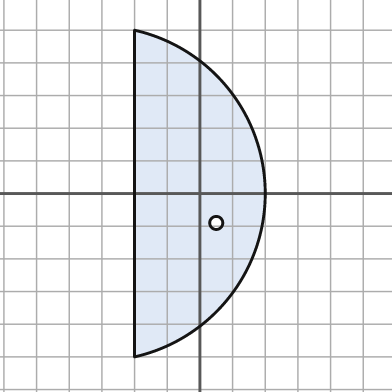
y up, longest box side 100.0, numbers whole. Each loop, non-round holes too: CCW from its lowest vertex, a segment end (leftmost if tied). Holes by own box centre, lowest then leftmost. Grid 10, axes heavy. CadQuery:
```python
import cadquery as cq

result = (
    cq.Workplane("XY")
    .moveTo(-20.0, -50.0)
    .threePointArc((20.0, 0.0), (-20.0, 50.0))
    .close()
    .moveTo(5.0, -9.0)
    .circle(2.0)
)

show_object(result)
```